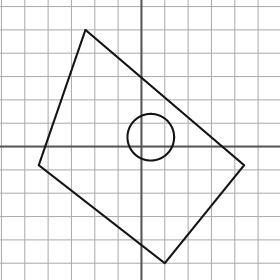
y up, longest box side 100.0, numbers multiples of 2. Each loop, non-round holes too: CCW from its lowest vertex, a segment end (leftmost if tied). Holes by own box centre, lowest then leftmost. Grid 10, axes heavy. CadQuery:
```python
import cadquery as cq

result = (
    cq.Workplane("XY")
    .moveTo(10.0, -50.0)
    .lineTo(44.0, -8.0)
    .lineTo(-24.0, 50.0)
    .lineTo(-44.0, -8.0)
    .close()
    .moveTo(4.0, 4.0)
    .circle(10.0)
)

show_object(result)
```